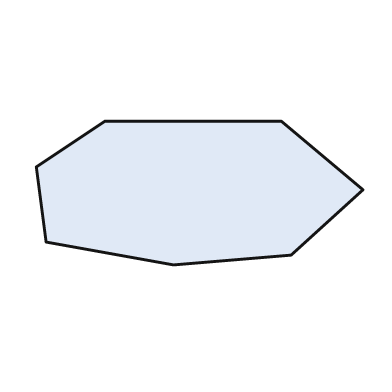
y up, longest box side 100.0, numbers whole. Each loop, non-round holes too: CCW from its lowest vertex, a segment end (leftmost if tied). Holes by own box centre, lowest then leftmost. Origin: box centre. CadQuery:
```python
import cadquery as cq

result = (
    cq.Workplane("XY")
    .moveTo(-8.0, -22.0)
    .lineTo(28.0, -19.0)
    .lineTo(50.0, 1.0)
    .lineTo(25.0, 22.0)
    .lineTo(-29.0, 22.0)
    .lineTo(-50.0, 8.0)
    .lineTo(-47.0, -15.0)
    .close()
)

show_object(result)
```